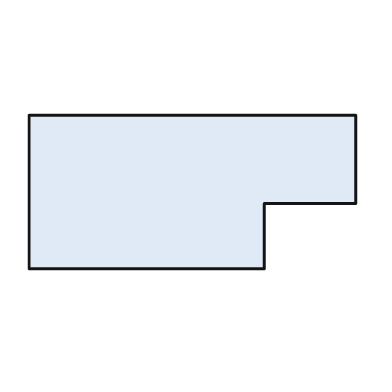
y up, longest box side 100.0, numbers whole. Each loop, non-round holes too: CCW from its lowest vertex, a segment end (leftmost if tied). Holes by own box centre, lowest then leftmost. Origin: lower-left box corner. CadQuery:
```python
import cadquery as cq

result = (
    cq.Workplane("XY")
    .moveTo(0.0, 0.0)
    .lineTo(72.0, 0.0)
    .lineTo(72.0, 20.0)
    .lineTo(100.0, 20.0)
    .lineTo(100.0, 47.0)
    .lineTo(0.0, 47.0)
    .close()
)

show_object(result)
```